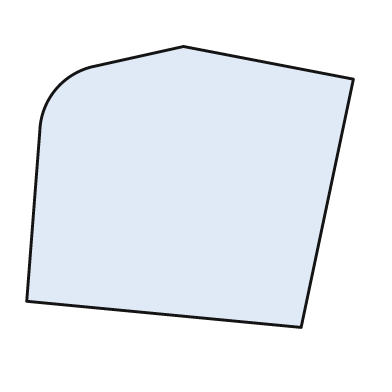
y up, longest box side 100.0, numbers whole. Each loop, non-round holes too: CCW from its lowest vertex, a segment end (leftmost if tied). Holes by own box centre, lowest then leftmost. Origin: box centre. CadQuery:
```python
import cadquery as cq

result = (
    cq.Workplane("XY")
    .moveTo(34.0, -43.0)
    .lineTo(50.0, 33.0)
    .lineTo(-2.0, 43.0)
    .lineTo(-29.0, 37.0)
    .threePointArc((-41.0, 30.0), (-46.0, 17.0))
    .lineTo(-50.0, -35.0)
    .close()
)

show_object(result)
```